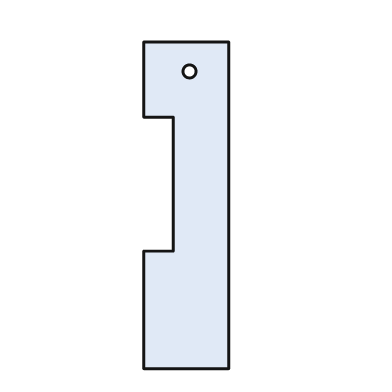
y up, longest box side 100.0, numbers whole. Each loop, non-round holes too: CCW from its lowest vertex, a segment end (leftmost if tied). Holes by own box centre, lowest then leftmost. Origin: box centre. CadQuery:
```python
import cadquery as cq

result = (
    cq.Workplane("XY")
    .moveTo(-13.0, -50.0)
    .lineTo(13.0, -50.0)
    .lineTo(13.0, 50.0)
    .lineTo(-13.0, 50.0)
    .lineTo(-13.0, 27.0)
    .lineTo(-4.0, 27.0)
    .lineTo(-4.0, -14.0)
    .lineTo(-13.0, -14.0)
    .close()
    .moveTo(1.0, 41.0)
    .circle(2.0)
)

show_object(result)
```